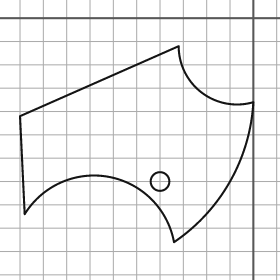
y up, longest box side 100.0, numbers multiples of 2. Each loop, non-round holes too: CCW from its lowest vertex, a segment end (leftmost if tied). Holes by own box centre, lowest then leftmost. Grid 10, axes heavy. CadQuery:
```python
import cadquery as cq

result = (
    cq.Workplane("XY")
    .moveTo(-34.0, -96.0)
    .threePointArc((-10.0, -70.0), (0.0, -36.0))
    .threePointArc((-22.0, -32.0), (-32.0, -12.0))
    .lineTo(-100.0, -42.0)
    .lineTo(-98.0, -84.0)
    .threePointArc((-62.0, -68.0), (-34.0, -96.0))
    .close()
    .moveTo(-40.0, -70.0)
    .circle(4.0)
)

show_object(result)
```